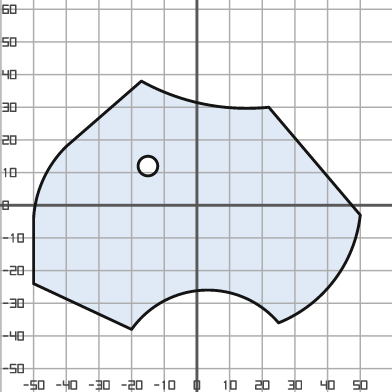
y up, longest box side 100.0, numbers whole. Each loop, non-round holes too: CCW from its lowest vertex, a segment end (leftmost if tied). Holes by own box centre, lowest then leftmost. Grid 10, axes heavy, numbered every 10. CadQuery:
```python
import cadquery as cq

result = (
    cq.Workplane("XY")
    .moveTo(-20.0, -38.0)
    .threePointArc((2.0, -26.0), (25.0, -36.0))
    .threePointArc((42.0, -23.0), (50.0, -3.0))
    .lineTo(22.0, 30.0)
    .threePointArc((2.0, 31.0), (-17.0, 38.0))
    .lineTo(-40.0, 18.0)
    .threePointArc((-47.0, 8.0), (-50.0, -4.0))
    .lineTo(-50.0, -24.0)
    .close()
    .moveTo(-15.0, 12.0)
    .circle(3.0)
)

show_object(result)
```